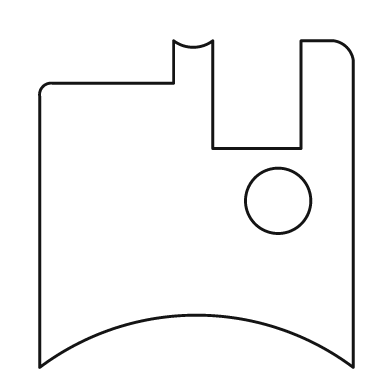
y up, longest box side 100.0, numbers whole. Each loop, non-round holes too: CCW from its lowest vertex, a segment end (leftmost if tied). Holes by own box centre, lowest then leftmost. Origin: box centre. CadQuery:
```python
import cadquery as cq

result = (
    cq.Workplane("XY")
    .moveTo(-48.0, -50.0)
    .threePointArc((0.0, -34.0), (48.0, -50.0))
    .lineTo(48.0, 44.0)
    .threePointArc((46.0, 48.0), (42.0, 50.0))
    .lineTo(32.0, 50.0)
    .lineTo(32.0, 17.0)
    .lineTo(5.0, 17.0)
    .lineTo(5.0, 50.0)
    .threePointArc((-1.0, 48.0), (-7.0, 50.0))
    .lineTo(-7.0, 37.0)
    .lineTo(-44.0, 37.0)
    .threePointArc((-47.0, 36.0), (-48.0, 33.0))
    .close()
    .moveTo(25.0, 1.0)
    .circle(10.0)
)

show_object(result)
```